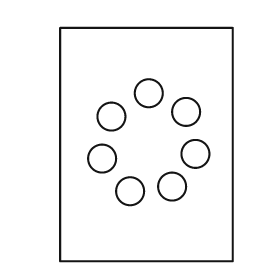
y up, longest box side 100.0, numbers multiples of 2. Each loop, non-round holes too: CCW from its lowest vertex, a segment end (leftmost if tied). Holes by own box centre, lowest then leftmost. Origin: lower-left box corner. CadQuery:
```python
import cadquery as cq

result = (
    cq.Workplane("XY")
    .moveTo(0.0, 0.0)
    .lineTo(74.0, 0.0)
    .lineTo(74.0, 100.0)
    .lineTo(0.0, 100.0)
    .close()
    .moveTo(30.0, 30.0)
    .circle(6.0)
    .moveTo(48.0, 32.0)
    .circle(6.0)
    .moveTo(18.0, 44.0)
    .circle(6.0)
    .moveTo(58.0, 46.0)
    .circle(6.0)
    .moveTo(22.0, 62.0)
    .circle(6.0)
    .moveTo(54.0, 64.0)
    .circle(6.0)
    .moveTo(38.0, 72.0)
    .circle(6.0)
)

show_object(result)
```